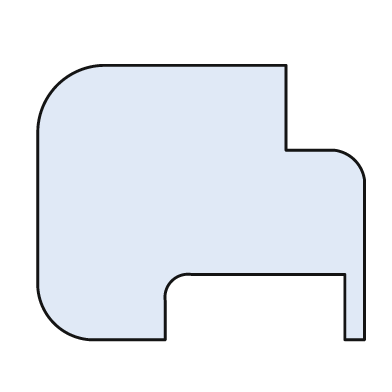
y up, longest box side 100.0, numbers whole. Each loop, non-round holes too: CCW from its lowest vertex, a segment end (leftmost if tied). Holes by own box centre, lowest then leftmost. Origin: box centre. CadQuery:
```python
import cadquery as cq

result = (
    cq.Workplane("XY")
    .moveTo(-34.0, -42.0)
    .lineTo(-11.0, -42.0)
    .lineTo(-11.0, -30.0)
    .threePointArc((-9.0, -24.0), (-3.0, -22.0))
    .lineTo(44.0, -22.0)
    .lineTo(44.0, -42.0)
    .lineTo(50.0, -42.0)
    .lineTo(50.0, 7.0)
    .threePointArc((47.0, 13.0), (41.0, 16.0))
    .lineTo(26.0, 16.0)
    .lineTo(26.0, 42.0)
    .lineTo(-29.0, 42.0)
    .threePointArc((-44.0, 36.0), (-50.0, 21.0))
    .lineTo(-50.0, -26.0)
    .threePointArc((-45.0, -37.0), (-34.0, -42.0))
    .close()
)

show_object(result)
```